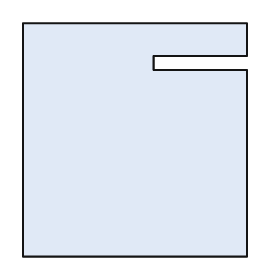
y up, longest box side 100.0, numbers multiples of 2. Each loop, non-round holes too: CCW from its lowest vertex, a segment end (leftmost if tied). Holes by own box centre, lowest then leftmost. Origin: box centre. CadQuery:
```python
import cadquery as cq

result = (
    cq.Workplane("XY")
    .moveTo(-48.0, -50.0)
    .lineTo(48.0, -50.0)
    .lineTo(48.0, 30.0)
    .lineTo(8.0, 30.0)
    .lineTo(8.0, 36.0)
    .lineTo(48.0, 36.0)
    .lineTo(48.0, 50.0)
    .lineTo(-48.0, 50.0)
    .close()
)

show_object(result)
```